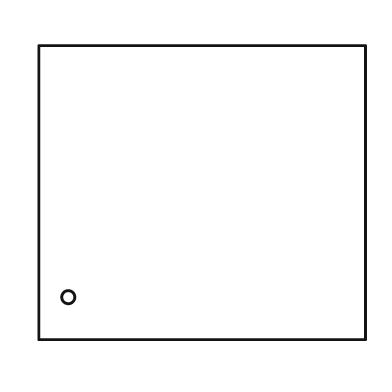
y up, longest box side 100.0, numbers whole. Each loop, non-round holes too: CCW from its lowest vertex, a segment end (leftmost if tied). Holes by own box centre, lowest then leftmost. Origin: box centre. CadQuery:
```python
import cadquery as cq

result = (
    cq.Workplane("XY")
    .moveTo(-50.0, -45.0)
    .lineTo(50.0, -45.0)
    .lineTo(50.0, 45.0)
    .lineTo(-50.0, 45.0)
    .close()
    .moveTo(-41.0, -32.0)
    .circle(2.0)
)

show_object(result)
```